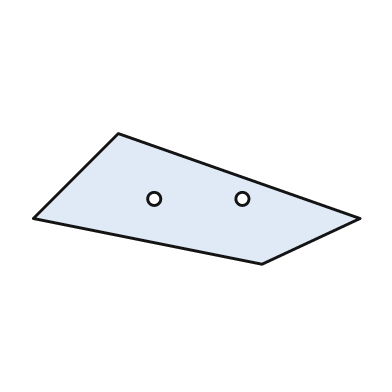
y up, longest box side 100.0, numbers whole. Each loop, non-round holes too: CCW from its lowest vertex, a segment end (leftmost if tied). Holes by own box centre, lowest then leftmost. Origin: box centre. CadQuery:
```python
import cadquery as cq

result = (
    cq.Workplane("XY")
    .moveTo(20.0, -20.0)
    .lineTo(50.0, -6.0)
    .lineTo(-24.0, 20.0)
    .lineTo(-50.0, -6.0)
    .close()
    .moveTo(-13.0, 0.0)
    .circle(2.0)
    .moveTo(14.0, 0.0)
    .circle(2.0)
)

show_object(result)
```